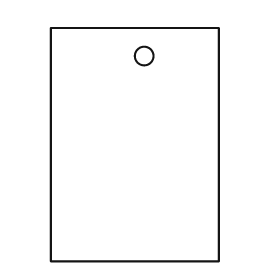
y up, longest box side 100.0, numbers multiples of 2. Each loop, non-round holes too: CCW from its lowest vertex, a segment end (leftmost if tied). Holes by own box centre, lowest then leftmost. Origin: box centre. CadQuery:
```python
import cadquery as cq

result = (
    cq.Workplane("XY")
    .moveTo(-36.0, -50.0)
    .lineTo(36.0, -50.0)
    .lineTo(36.0, 50.0)
    .lineTo(-36.0, 50.0)
    .close()
    .moveTo(4.0, 38.0)
    .circle(4.0)
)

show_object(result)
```